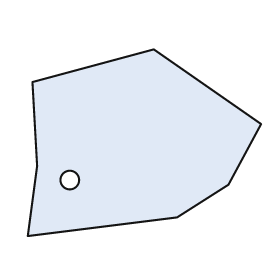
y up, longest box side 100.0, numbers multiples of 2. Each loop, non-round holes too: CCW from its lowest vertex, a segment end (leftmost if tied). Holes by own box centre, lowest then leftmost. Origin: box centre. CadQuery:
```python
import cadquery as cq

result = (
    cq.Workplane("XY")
    .moveTo(-50.0, -40.0)
    .lineTo(14.0, -32.0)
    .lineTo(36.0, -18.0)
    .lineTo(50.0, 8.0)
    .lineTo(4.0, 40.0)
    .lineTo(-48.0, 26.0)
    .lineTo(-46.0, -10.0)
    .close()
    .moveTo(-32.0, -16.0)
    .circle(4.0)
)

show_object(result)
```